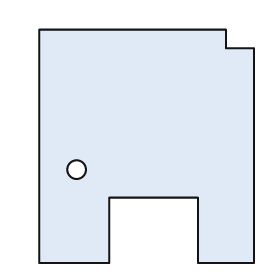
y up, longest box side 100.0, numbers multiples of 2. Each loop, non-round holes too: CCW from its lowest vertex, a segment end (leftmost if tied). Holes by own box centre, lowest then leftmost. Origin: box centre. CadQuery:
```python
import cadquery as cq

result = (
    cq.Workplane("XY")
    .moveTo(-46.0, -50.0)
    .lineTo(-16.0, -50.0)
    .lineTo(-16.0, -22.0)
    .lineTo(22.0, -22.0)
    .lineTo(22.0, -50.0)
    .lineTo(46.0, -50.0)
    .lineTo(46.0, 42.0)
    .lineTo(34.0, 42.0)
    .lineTo(34.0, 50.0)
    .lineTo(-46.0, 50.0)
    .close()
    .moveTo(-30.0, -10.0)
    .circle(4.0)
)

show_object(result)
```